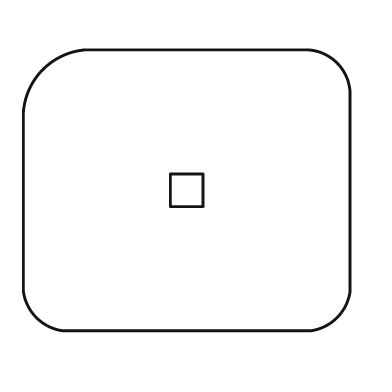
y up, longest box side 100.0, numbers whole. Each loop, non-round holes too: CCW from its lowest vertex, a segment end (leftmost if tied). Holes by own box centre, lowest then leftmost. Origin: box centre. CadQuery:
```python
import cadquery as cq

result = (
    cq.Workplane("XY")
    .moveTo(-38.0, -43.0)
    .lineTo(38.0, -43.0)
    .threePointArc((46.0, -39.0), (50.0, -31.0))
    .lineTo(50.0, 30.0)
    .threePointArc((46.0, 39.0), (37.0, 43.0))
    .lineTo(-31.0, 43.0)
    .threePointArc((-44.0, 37.0), (-50.0, 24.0))
    .lineTo(-50.0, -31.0)
    .threePointArc((-46.0, -39.0), (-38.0, -43.0))
    .close()
    .moveTo(-5.0, -5.0)
    .lineTo(5.0, -5.0)
    .lineTo(5.0, 5.0)
    .lineTo(-5.0, 5.0)
    .close()
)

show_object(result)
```